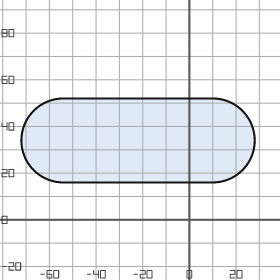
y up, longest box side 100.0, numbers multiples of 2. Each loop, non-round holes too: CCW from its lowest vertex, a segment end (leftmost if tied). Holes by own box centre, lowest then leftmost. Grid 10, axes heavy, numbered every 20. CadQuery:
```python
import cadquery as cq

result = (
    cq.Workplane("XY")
    .moveTo(-54.0, 16.0)
    .lineTo(10.0, 16.0)
    .threePointArc((28.0, 34.0), (10.0, 52.0))
    .lineTo(-54.0, 52.0)
    .threePointArc((-72.0, 34.0), (-54.0, 16.0))
    .close()
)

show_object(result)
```